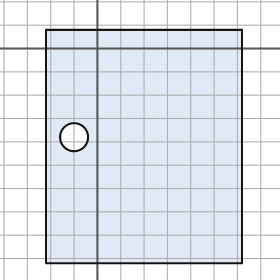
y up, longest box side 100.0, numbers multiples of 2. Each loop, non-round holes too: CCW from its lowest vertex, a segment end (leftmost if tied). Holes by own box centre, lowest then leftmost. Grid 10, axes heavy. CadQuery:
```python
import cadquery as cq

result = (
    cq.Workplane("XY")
    .moveTo(-22.0, -92.0)
    .lineTo(62.0, -92.0)
    .lineTo(62.0, 8.0)
    .lineTo(-22.0, 8.0)
    .close()
    .moveTo(-10.0, -38.0)
    .circle(6.0)
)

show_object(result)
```